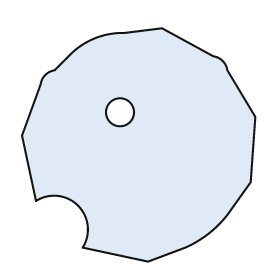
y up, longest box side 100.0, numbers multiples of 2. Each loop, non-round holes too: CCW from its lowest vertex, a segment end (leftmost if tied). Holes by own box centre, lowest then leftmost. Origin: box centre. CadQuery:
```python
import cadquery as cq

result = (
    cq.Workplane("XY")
    .moveTo(4.0, -50.0)
    .lineTo(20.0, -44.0)
    .threePointArc((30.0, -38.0), (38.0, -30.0))
    .lineTo(48.0, -16.0)
    .lineTo(50.0, 12.0)
    .lineTo(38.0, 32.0)
    .threePointArc((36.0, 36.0), (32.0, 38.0))
    .lineTo(10.0, 50.0)
    .lineTo(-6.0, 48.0)
    .threePointArc((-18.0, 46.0), (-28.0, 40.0))
    .lineTo(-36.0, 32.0)
    .threePointArc((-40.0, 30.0), (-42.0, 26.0))
    .lineTo(-50.0, 4.0)
    .lineTo(-44.0, -24.0)
    .threePointArc((-26.0, -26.0), (-24.0, -44.0))
    .close()
    .moveTo(-8.0, 14.0)
    .circle(6.0)
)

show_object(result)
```